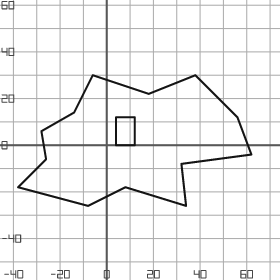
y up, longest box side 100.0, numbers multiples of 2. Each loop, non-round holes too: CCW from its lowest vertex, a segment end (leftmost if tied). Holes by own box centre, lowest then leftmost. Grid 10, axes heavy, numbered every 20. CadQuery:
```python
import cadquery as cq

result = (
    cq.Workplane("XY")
    .moveTo(-8.0, -26.0)
    .lineTo(8.0, -18.0)
    .lineTo(34.0, -26.0)
    .lineTo(32.0, -8.0)
    .lineTo(62.0, -4.0)
    .lineTo(56.0, 12.0)
    .lineTo(38.0, 30.0)
    .lineTo(18.0, 22.0)
    .lineTo(-6.0, 30.0)
    .lineTo(-14.0, 14.0)
    .lineTo(-28.0, 6.0)
    .lineTo(-26.0, -6.0)
    .lineTo(-38.0, -18.0)
    .close()
    .moveTo(4.0, 0.0)
    .lineTo(12.0, 0.0)
    .lineTo(12.0, 12.0)
    .lineTo(4.0, 12.0)
    .close()
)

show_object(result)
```